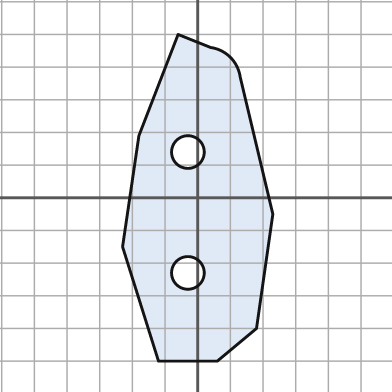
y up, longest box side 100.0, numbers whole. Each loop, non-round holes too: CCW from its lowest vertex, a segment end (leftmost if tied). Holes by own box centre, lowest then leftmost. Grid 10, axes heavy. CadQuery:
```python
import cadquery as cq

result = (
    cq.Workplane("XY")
    .moveTo(-12.0, -50.0)
    .lineTo(6.0, -50.0)
    .lineTo(18.0, -40.0)
    .lineTo(23.0, -5.0)
    .lineTo(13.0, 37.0)
    .threePointArc((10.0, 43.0), (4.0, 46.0))
    .lineTo(-6.0, 50.0)
    .lineTo(-18.0, 19.0)
    .lineTo(-23.0, -15.0)
    .close()
    .moveTo(-3.0, -23.0)
    .circle(5.0)
    .moveTo(-3.0, 14.0)
    .circle(5.0)
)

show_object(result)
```